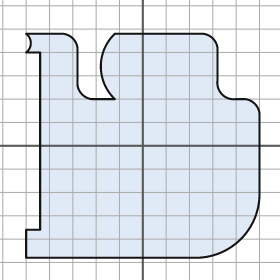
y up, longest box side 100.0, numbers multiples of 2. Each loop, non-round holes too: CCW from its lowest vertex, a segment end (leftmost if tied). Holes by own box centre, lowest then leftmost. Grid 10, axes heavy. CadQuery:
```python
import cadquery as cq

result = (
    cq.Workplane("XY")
    .moveTo(-50.0, -48.0)
    .lineTo(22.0, -48.0)
    .threePointArc((42.0, -40.0), (50.0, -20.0))
    .lineTo(50.0, 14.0)
    .threePointArc((48.0, 18.0), (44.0, 20.0))
    .lineTo(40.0, 20.0)
    .threePointArc((34.0, 22.0), (32.0, 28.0))
    .lineTo(32.0, 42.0)
    .threePointArc((30.0, 46.0), (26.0, 48.0))
    .lineTo(-12.0, 48.0)
    .threePointArc((-18.0, 34.0), (-12.0, 20.0))
    .lineTo(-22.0, 20.0)
    .threePointArc((-26.0, 22.0), (-28.0, 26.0))
    .lineTo(-28.0, 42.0)
    .threePointArc((-30.0, 46.0), (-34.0, 48.0))
    .lineTo(-50.0, 48.0)
    .threePointArc((-48.0, 44.0), (-50.0, 40.0))
    .lineTo(-44.0, 40.0)
    .lineTo(-44.0, -36.0)
    .lineTo(-50.0, -36.0)
    .close()
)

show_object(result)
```